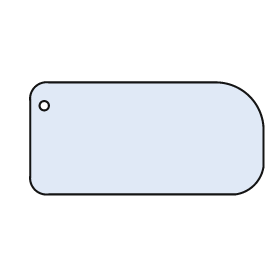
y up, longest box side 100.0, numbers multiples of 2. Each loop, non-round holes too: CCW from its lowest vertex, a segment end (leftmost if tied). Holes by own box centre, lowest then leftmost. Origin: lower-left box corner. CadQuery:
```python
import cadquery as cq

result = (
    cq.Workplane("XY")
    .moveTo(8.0, 0.0)
    .lineTo(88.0, 0.0)
    .threePointArc((96.0, 4.0), (100.0, 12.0))
    .lineTo(100.0, 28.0)
    .threePointArc((94.0, 42.0), (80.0, 48.0))
    .lineTo(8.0, 48.0)
    .threePointArc((2.0, 46.0), (0.0, 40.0))
    .lineTo(0.0, 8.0)
    .threePointArc((2.0, 2.0), (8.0, 0.0))
    .close()
    .moveTo(6.0, 38.0)
    .circle(2.0)
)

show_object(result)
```